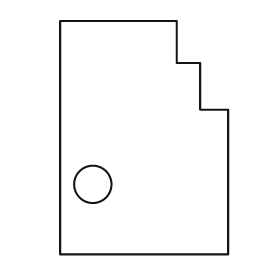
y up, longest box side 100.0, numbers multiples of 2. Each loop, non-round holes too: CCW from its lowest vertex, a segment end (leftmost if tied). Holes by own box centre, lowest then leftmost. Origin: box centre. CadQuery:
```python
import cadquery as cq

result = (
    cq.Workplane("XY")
    .moveTo(-36.0, -50.0)
    .lineTo(36.0, -50.0)
    .lineTo(36.0, 12.0)
    .lineTo(24.0, 12.0)
    .lineTo(24.0, 32.0)
    .lineTo(14.0, 32.0)
    .lineTo(14.0, 50.0)
    .lineTo(-36.0, 50.0)
    .close()
    .moveTo(-22.0, -20.0)
    .circle(8.0)
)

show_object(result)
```